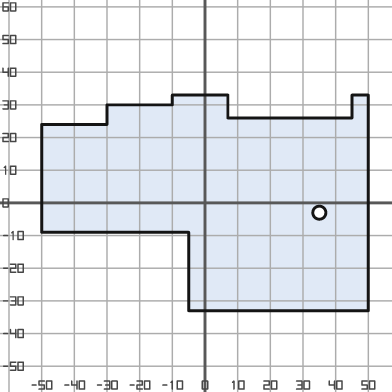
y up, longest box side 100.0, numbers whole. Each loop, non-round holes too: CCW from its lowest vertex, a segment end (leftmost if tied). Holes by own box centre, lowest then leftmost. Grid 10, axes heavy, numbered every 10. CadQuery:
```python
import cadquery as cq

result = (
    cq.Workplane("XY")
    .moveTo(-5.0, -33.0)
    .lineTo(50.0, -33.0)
    .lineTo(50.0, 33.0)
    .lineTo(45.0, 33.0)
    .lineTo(45.0, 26.0)
    .lineTo(7.0, 26.0)
    .lineTo(7.0, 33.0)
    .lineTo(-10.0, 33.0)
    .lineTo(-10.0, 30.0)
    .lineTo(-30.0, 30.0)
    .lineTo(-30.0, 24.0)
    .lineTo(-50.0, 24.0)
    .lineTo(-50.0, -9.0)
    .lineTo(-5.0, -9.0)
    .close()
    .moveTo(35.0, -3.0)
    .circle(2.0)
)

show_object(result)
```